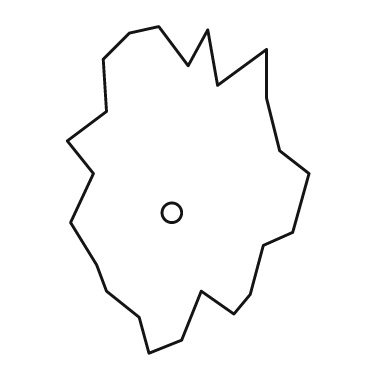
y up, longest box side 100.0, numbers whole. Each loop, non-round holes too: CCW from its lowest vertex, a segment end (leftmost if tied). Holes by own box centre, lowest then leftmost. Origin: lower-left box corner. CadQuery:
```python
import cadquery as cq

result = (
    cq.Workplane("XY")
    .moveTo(25.0, 0.0)
    .lineTo(35.0, 4.0)
    .lineTo(41.0, 19.0)
    .lineTo(51.0, 12.0)
    .lineTo(56.0, 18.0)
    .lineTo(60.0, 33.0)
    .lineTo(69.0, 37.0)
    .lineTo(74.0, 55.0)
    .lineTo(65.0, 62.0)
    .lineTo(61.0, 78.0)
    .lineTo(61.0, 93.0)
    .lineTo(46.0, 82.0)
    .lineTo(43.0, 99.0)
    .lineTo(37.0, 88.0)
    .lineTo(28.0, 100.0)
    .lineTo(19.0, 98.0)
    .lineTo(11.0, 90.0)
    .lineTo(12.0, 74.0)
    .lineTo(0.0, 65.0)
    .lineTo(8.0, 55.0)
    .lineTo(1.0, 40.0)
    .lineTo(9.0, 27.0)
    .lineTo(12.0, 19.0)
    .lineTo(22.0, 11.0)
    .close()
    .moveTo(32.0, 43.0)
    .circle(3.0)
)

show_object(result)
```